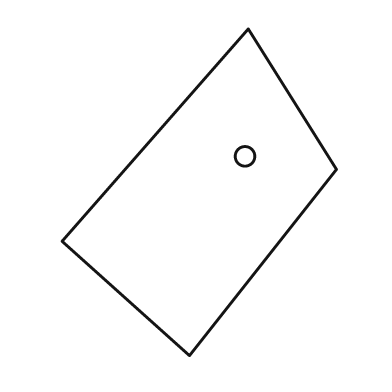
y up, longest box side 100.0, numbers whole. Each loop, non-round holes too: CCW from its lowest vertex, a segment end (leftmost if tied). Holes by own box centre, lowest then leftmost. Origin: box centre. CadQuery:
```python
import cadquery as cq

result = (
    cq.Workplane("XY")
    .moveTo(-3.0, -50.0)
    .lineTo(42.0, 7.0)
    .lineTo(15.0, 50.0)
    .lineTo(-42.0, -15.0)
    .close()
    .moveTo(14.0, 11.0)
    .circle(3.0)
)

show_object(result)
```